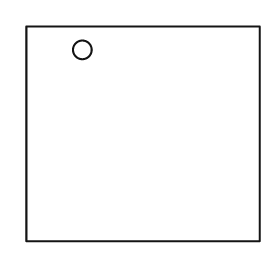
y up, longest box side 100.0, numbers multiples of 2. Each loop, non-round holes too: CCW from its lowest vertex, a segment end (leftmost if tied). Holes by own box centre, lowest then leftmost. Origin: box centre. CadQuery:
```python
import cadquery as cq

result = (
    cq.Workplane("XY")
    .moveTo(-50.0, -46.0)
    .lineTo(50.0, -46.0)
    .lineTo(50.0, 46.0)
    .lineTo(-50.0, 46.0)
    .close()
    .moveTo(-26.0, 36.0)
    .circle(4.0)
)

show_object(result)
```